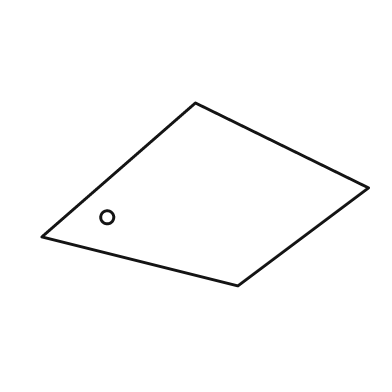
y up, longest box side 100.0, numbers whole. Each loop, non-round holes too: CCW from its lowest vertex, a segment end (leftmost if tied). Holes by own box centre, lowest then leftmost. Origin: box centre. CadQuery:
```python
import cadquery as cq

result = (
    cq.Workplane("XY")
    .moveTo(10.0, -28.0)
    .lineTo(50.0, 2.0)
    .lineTo(-3.0, 28.0)
    .lineTo(-50.0, -13.0)
    .close()
    .moveTo(-30.0, -7.0)
    .circle(2.0)
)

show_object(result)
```